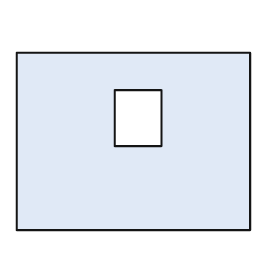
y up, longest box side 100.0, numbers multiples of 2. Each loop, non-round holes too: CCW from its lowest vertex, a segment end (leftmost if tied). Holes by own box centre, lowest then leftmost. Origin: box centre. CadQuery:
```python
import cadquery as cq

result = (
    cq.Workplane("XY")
    .moveTo(-50.0, -38.0)
    .lineTo(50.0, -38.0)
    .lineTo(50.0, 38.0)
    .lineTo(-50.0, 38.0)
    .close()
    .moveTo(-8.0, -2.0)
    .lineTo(12.0, -2.0)
    .lineTo(12.0, 22.0)
    .lineTo(-8.0, 22.0)
    .close()
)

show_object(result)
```